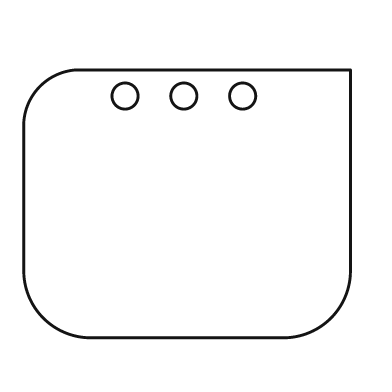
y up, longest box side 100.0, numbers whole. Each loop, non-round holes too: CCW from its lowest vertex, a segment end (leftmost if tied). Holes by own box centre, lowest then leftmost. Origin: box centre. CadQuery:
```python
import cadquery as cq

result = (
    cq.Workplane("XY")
    .moveTo(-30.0, -41.0)
    .lineTo(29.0, -41.0)
    .threePointArc((44.0, -35.0), (50.0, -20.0))
    .lineTo(50.0, 41.0)
    .lineTo(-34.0, 41.0)
    .threePointArc((-45.0, 36.0), (-50.0, 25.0))
    .lineTo(-50.0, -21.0)
    .threePointArc((-44.0, -35.0), (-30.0, -41.0))
    .close()
    .moveTo(-19.0, 33.0)
    .circle(4.0)
    .moveTo(-1.0, 33.0)
    .circle(4.0)
    .moveTo(17.0, 33.0)
    .circle(4.0)
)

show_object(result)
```